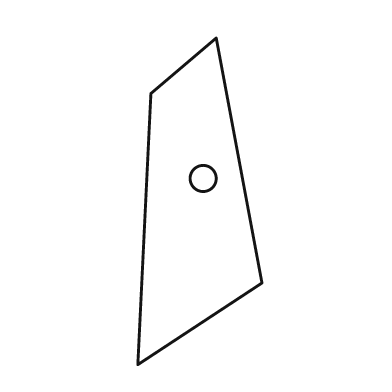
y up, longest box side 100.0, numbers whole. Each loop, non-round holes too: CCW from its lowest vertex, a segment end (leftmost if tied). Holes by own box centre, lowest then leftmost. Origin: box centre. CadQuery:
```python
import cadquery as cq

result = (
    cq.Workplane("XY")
    .moveTo(-19.0, -50.0)
    .lineTo(19.0, -25.0)
    .lineTo(5.0, 50.0)
    .lineTo(-15.0, 33.0)
    .close()
    .moveTo(1.0, 7.0)
    .circle(4.0)
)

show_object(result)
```